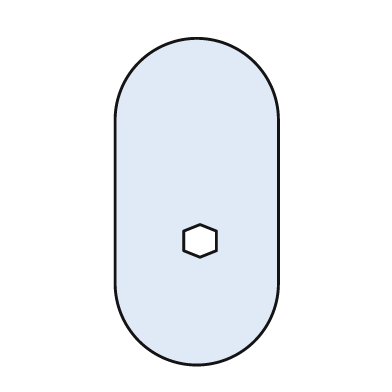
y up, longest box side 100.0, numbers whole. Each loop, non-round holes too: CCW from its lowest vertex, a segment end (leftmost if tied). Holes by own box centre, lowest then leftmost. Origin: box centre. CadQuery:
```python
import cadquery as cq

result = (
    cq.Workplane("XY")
    .moveTo(-25.0, -25.0)
    .threePointArc((0.0, -50.0), (25.0, -25.0))
    .lineTo(25.0, 25.0)
    .threePointArc((0.0, 50.0), (-25.0, 25.0))
    .close()
    .moveTo(1.0, -17.0)
    .lineTo(6.0, -15.0)
    .lineTo(6.0, -9.0)
    .lineTo(1.0, -7.0)
    .lineTo(-4.0, -9.0)
    .lineTo(-4.0, -15.0)
    .close()
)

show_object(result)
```